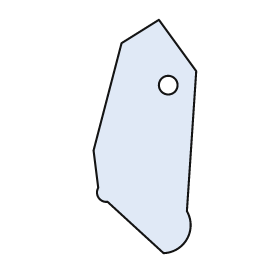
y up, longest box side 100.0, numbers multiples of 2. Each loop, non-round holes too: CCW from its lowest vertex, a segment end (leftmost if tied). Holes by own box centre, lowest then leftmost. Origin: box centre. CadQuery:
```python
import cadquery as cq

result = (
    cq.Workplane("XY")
    .moveTo(8.0, -50.0)
    .threePointArc((18.0, -44.0), (18.0, -32.0))
    .lineTo(22.0, 28.0)
    .lineTo(6.0, 50.0)
    .lineTo(-10.0, 40.0)
    .lineTo(-22.0, -6.0)
    .lineTo(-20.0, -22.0)
    .threePointArc((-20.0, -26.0), (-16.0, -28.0))
    .close()
    .moveTo(10.0, 22.0)
    .circle(4.0)
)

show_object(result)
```